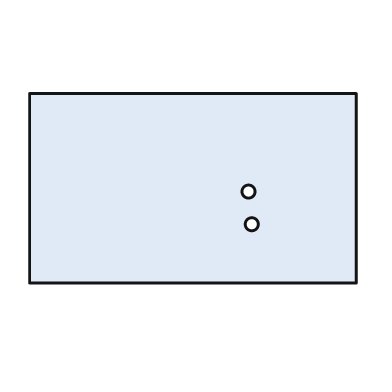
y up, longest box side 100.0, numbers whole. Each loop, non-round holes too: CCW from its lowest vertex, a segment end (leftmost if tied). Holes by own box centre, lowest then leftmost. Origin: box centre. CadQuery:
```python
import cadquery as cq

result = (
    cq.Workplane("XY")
    .moveTo(-50.0, -29.0)
    .lineTo(50.0, -29.0)
    .lineTo(50.0, 29.0)
    .lineTo(-50.0, 29.0)
    .close()
    .moveTo(18.0, -11.0)
    .circle(2.0)
    .moveTo(17.0, -1.0)
    .circle(2.0)
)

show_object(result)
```